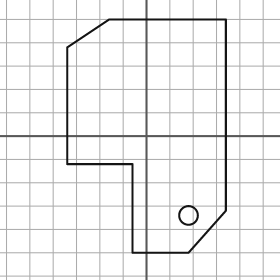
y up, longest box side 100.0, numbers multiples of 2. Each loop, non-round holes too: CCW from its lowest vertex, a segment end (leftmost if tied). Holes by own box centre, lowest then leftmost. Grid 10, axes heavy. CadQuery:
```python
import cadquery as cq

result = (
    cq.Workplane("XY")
    .moveTo(-6.0, -50.0)
    .lineTo(18.0, -50.0)
    .lineTo(34.0, -32.0)
    .lineTo(34.0, 50.0)
    .lineTo(-16.0, 50.0)
    .lineTo(-34.0, 38.0)
    .lineTo(-34.0, -12.0)
    .lineTo(-6.0, -12.0)
    .close()
    .moveTo(18.0, -34.0)
    .circle(4.0)
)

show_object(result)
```